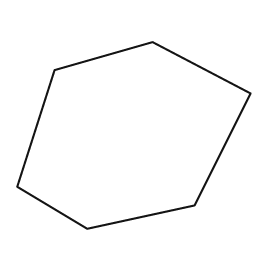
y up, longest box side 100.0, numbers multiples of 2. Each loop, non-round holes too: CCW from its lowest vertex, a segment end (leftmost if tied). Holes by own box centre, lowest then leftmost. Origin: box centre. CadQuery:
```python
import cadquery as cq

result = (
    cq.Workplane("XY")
    .moveTo(-20.0, -40.0)
    .lineTo(26.0, -30.0)
    .lineTo(50.0, 18.0)
    .lineTo(8.0, 40.0)
    .lineTo(-34.0, 28.0)
    .lineTo(-50.0, -22.0)
    .close()
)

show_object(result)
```